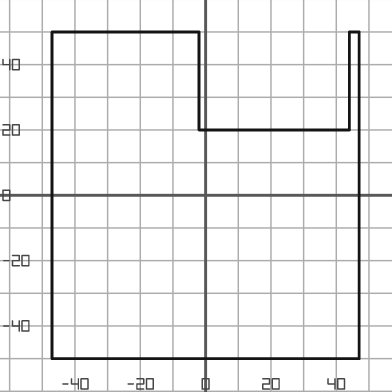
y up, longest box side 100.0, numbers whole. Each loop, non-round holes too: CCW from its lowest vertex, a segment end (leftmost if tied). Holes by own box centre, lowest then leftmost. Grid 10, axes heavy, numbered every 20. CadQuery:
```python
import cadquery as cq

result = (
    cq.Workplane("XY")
    .moveTo(-47.0, -50.0)
    .lineTo(47.0, -50.0)
    .lineTo(47.0, 50.0)
    .lineTo(44.0, 50.0)
    .lineTo(44.0, 20.0)
    .lineTo(-2.0, 20.0)
    .lineTo(-2.0, 50.0)
    .lineTo(-47.0, 50.0)
    .close()
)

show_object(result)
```